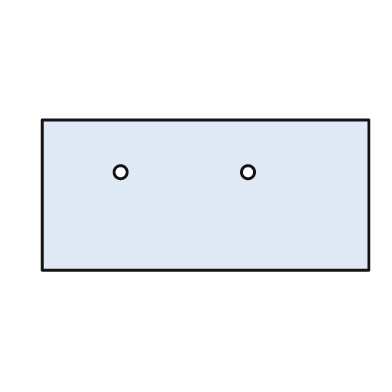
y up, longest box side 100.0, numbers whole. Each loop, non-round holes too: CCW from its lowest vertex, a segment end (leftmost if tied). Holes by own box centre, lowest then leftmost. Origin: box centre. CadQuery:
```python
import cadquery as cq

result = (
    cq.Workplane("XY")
    .moveTo(-50.0, -23.0)
    .lineTo(50.0, -23.0)
    .lineTo(50.0, 23.0)
    .lineTo(-50.0, 23.0)
    .close()
    .moveTo(-26.0, 7.0)
    .circle(2.0)
    .moveTo(13.0, 7.0)
    .circle(2.0)
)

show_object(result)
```